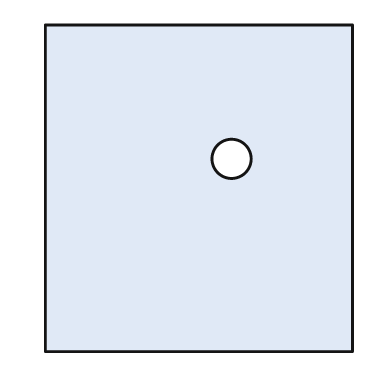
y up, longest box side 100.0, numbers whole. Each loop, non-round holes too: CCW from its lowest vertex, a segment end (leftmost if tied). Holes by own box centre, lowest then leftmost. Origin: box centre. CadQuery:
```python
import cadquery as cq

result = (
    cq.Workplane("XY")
    .moveTo(-47.0, -50.0)
    .lineTo(47.0, -50.0)
    .lineTo(47.0, 50.0)
    .lineTo(-47.0, 50.0)
    .close()
    .moveTo(10.0, 9.0)
    .circle(6.0)
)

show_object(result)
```